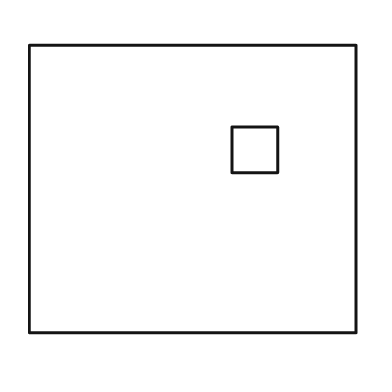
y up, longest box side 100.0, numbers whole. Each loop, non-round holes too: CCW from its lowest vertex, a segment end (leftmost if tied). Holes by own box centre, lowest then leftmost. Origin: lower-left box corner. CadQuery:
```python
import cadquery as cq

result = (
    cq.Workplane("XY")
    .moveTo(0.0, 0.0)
    .lineTo(100.0, 0.0)
    .lineTo(100.0, 88.0)
    .lineTo(0.0, 88.0)
    .close()
    .moveTo(62.0, 49.0)
    .lineTo(76.0, 49.0)
    .lineTo(76.0, 63.0)
    .lineTo(62.0, 63.0)
    .close()
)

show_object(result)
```